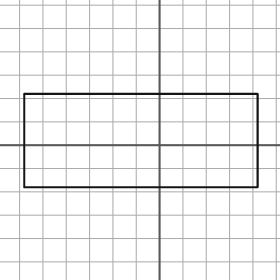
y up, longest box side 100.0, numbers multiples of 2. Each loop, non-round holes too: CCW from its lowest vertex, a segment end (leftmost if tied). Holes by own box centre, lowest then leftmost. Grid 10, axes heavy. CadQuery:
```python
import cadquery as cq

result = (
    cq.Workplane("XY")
    .moveTo(-58.0, -18.0)
    .lineTo(42.0, -18.0)
    .lineTo(42.0, 22.0)
    .lineTo(-58.0, 22.0)
    .close()
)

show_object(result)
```